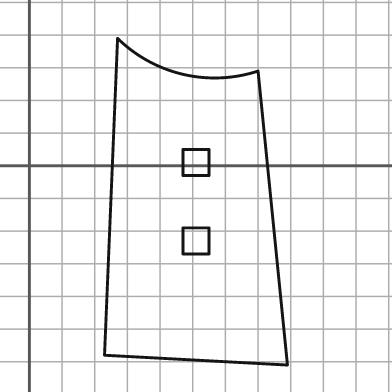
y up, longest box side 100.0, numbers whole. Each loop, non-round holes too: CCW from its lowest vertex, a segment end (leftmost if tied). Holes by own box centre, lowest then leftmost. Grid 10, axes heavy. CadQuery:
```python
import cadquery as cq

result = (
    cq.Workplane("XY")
    .moveTo(79.0, -61.0)
    .lineTo(70.0, 29.0)
    .threePointArc((47.0, 28.0), (27.0, 39.0))
    .lineTo(23.0, -58.0)
    .close()
    .moveTo(47.0, -27.0)
    .lineTo(55.0, -27.0)
    .lineTo(55.0, -19.0)
    .lineTo(47.0, -19.0)
    .close()
    .moveTo(47.0, -3.0)
    .lineTo(55.0, -3.0)
    .lineTo(55.0, 5.0)
    .lineTo(47.0, 5.0)
    .close()
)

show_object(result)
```